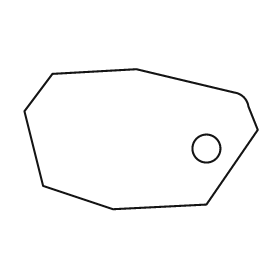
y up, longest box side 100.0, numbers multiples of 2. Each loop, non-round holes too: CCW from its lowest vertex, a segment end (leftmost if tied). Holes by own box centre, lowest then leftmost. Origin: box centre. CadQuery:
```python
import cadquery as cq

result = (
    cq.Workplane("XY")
    .moveTo(-12.0, -30.0)
    .lineTo(28.0, -28.0)
    .lineTo(50.0, 4.0)
    .lineTo(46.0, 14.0)
    .threePointArc((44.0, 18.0), (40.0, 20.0))
    .lineTo(-2.0, 30.0)
    .lineTo(-38.0, 28.0)
    .lineTo(-50.0, 12.0)
    .lineTo(-42.0, -20.0)
    .close()
    .moveTo(28.0, -4.0)
    .circle(6.0)
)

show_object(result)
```